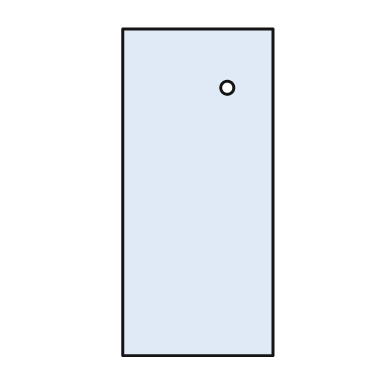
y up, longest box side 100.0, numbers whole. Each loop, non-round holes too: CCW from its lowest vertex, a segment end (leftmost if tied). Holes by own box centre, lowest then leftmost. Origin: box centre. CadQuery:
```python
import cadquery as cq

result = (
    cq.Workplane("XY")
    .moveTo(-23.0, -50.0)
    .lineTo(23.0, -50.0)
    .lineTo(23.0, 50.0)
    .lineTo(-23.0, 50.0)
    .close()
    .moveTo(9.0, 32.0)
    .circle(2.0)
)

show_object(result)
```